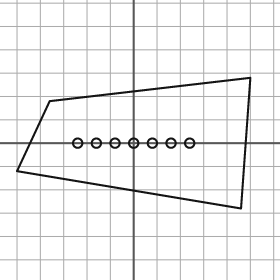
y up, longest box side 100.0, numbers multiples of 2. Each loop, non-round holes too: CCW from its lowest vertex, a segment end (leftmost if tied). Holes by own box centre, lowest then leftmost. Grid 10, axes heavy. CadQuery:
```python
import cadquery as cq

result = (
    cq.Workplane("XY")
    .moveTo(46.0, -28.0)
    .lineTo(50.0, 28.0)
    .lineTo(-36.0, 18.0)
    .lineTo(-50.0, -12.0)
    .close()
    .moveTo(-24.0, 0.0)
    .circle(2.0)
    .moveTo(-16.0, 0.0)
    .circle(2.0)
    .moveTo(-8.0, 0.0)
    .circle(2.0)
    .moveTo(0.0, 0.0)
    .circle(2.0)
    .moveTo(8.0, 0.0)
    .circle(2.0)
    .moveTo(16.0, 0.0)
    .circle(2.0)
    .moveTo(24.0, 0.0)
    .circle(2.0)
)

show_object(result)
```